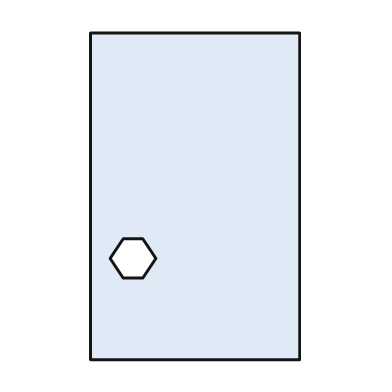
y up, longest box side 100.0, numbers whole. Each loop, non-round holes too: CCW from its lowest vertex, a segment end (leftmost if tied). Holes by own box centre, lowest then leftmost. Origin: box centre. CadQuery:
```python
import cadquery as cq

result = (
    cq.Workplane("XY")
    .moveTo(-32.0, -50.0)
    .lineTo(32.0, -50.0)
    .lineTo(32.0, 50.0)
    .lineTo(-32.0, 50.0)
    .close()
    .moveTo(-22.0, -25.0)
    .lineTo(-16.0, -25.0)
    .lineTo(-12.0, -19.0)
    .lineTo(-16.0, -13.0)
    .lineTo(-22.0, -13.0)
    .lineTo(-26.0, -19.0)
    .close()
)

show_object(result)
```